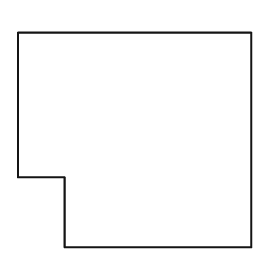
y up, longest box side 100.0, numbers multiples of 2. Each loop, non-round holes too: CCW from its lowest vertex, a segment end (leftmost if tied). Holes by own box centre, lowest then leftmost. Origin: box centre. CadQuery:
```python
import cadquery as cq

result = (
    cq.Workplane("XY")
    .moveTo(-30.0, -46.0)
    .lineTo(50.0, -46.0)
    .lineTo(50.0, 46.0)
    .lineTo(-50.0, 46.0)
    .lineTo(-50.0, -16.0)
    .lineTo(-30.0, -16.0)
    .close()
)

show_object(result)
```